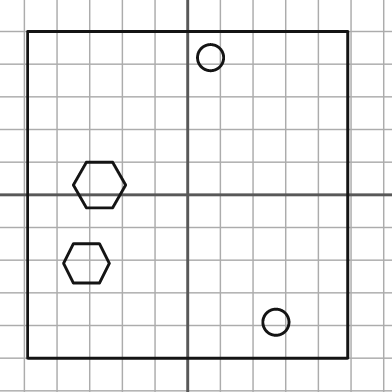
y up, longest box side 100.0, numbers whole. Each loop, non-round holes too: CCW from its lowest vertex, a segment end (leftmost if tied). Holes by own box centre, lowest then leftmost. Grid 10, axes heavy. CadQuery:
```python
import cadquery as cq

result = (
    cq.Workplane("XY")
    .moveTo(-49.0, -50.0)
    .lineTo(49.0, -50.0)
    .lineTo(49.0, 50.0)
    .lineTo(-49.0, 50.0)
    .close()
    .moveTo(27.0, -39.0)
    .circle(4.0)
    .moveTo(-35.0, -27.0)
    .lineTo(-27.0, -27.0)
    .lineTo(-24.0, -21.0)
    .lineTo(-27.0, -15.0)
    .lineTo(-35.0, -15.0)
    .lineTo(-38.0, -21.0)
    .close()
    .moveTo(-31.0, -4.0)
    .lineTo(-23.0, -4.0)
    .lineTo(-19.0, 3.0)
    .lineTo(-23.0, 10.0)
    .lineTo(-31.0, 10.0)
    .lineTo(-35.0, 3.0)
    .close()
    .moveTo(7.0, 42.0)
    .circle(4.0)
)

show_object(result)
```